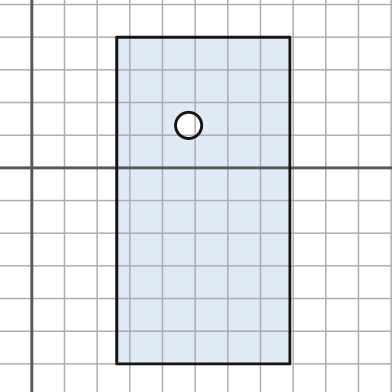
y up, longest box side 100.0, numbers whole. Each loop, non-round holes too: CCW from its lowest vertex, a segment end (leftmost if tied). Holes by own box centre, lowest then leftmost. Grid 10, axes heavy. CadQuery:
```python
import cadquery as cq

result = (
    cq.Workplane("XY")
    .moveTo(26.0, -60.0)
    .lineTo(79.0, -60.0)
    .lineTo(79.0, 40.0)
    .lineTo(26.0, 40.0)
    .close()
    .moveTo(48.0, 13.0)
    .circle(4.0)
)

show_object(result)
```